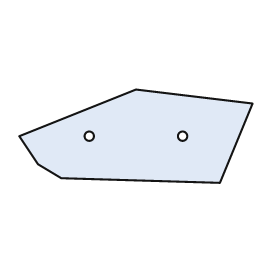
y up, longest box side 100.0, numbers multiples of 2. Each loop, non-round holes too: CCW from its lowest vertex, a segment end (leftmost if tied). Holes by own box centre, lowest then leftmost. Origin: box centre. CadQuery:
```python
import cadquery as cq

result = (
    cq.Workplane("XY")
    .moveTo(36.0, -20.0)
    .lineTo(50.0, 14.0)
    .lineTo(0.0, 20.0)
    .lineTo(-50.0, 0.0)
    .lineTo(-42.0, -12.0)
    .lineTo(-32.0, -18.0)
    .close()
    .moveTo(-20.0, 0.0)
    .circle(2.0)
    .moveTo(20.0, 0.0)
    .circle(2.0)
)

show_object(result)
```